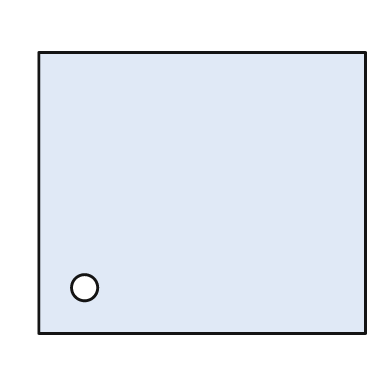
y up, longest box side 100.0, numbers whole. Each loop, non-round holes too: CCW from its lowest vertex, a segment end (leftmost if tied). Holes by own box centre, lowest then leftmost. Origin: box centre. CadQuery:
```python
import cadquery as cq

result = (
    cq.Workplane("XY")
    .moveTo(-50.0, -43.0)
    .lineTo(50.0, -43.0)
    .lineTo(50.0, 43.0)
    .lineTo(-50.0, 43.0)
    .close()
    .moveTo(-36.0, -29.0)
    .circle(4.0)
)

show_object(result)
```